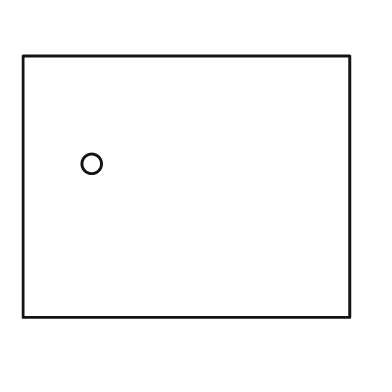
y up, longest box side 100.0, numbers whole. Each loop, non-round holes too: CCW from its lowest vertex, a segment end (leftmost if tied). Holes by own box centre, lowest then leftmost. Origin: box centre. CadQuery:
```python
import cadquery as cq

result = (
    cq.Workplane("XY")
    .moveTo(-50.0, -40.0)
    .lineTo(50.0, -40.0)
    .lineTo(50.0, 40.0)
    .lineTo(-50.0, 40.0)
    .close()
    .moveTo(-29.0, 7.0)
    .circle(3.0)
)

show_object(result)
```